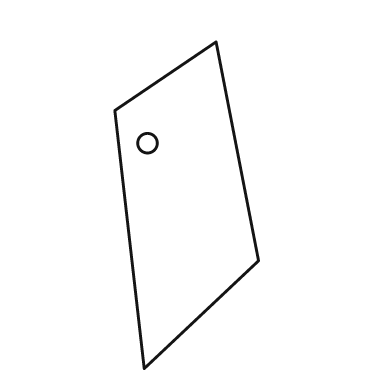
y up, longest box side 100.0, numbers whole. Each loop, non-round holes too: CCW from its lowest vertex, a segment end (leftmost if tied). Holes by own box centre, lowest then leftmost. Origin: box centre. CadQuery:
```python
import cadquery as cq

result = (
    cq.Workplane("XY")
    .moveTo(-13.0, -50.0)
    .lineTo(22.0, -17.0)
    .lineTo(9.0, 50.0)
    .lineTo(-22.0, 29.0)
    .close()
    .moveTo(-12.0, 19.0)
    .circle(3.0)
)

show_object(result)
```